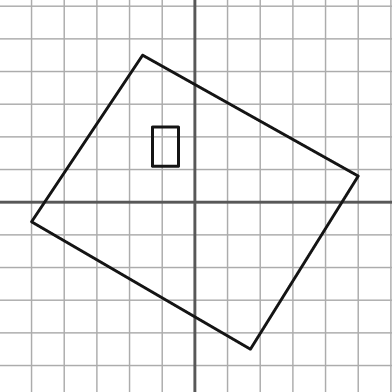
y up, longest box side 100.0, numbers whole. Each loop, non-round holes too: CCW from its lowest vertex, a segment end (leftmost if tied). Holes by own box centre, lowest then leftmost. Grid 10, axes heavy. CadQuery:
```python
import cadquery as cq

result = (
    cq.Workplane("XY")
    .moveTo(17.0, -45.0)
    .lineTo(50.0, 8.0)
    .lineTo(-16.0, 45.0)
    .lineTo(-50.0, -6.0)
    .close()
    .moveTo(-13.0, 11.0)
    .lineTo(-5.0, 11.0)
    .lineTo(-5.0, 23.0)
    .lineTo(-13.0, 23.0)
    .close()
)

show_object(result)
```